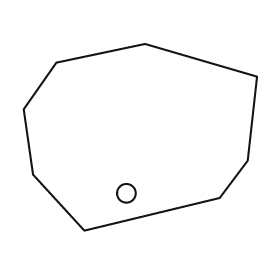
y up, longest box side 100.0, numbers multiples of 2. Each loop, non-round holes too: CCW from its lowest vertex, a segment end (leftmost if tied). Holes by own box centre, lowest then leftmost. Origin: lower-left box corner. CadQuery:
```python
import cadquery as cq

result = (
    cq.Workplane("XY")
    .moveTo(26.0, 0.0)
    .lineTo(84.0, 14.0)
    .lineTo(96.0, 30.0)
    .lineTo(100.0, 66.0)
    .lineTo(52.0, 80.0)
    .lineTo(14.0, 72.0)
    .lineTo(0.0, 52.0)
    .lineTo(4.0, 24.0)
    .close()
    .moveTo(44.0, 16.0)
    .circle(4.0)
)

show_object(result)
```